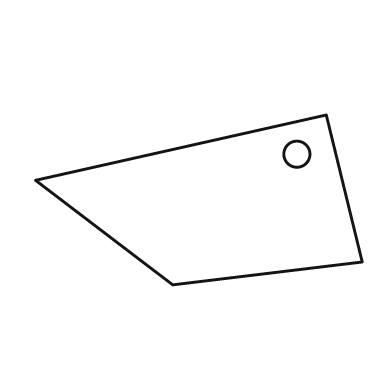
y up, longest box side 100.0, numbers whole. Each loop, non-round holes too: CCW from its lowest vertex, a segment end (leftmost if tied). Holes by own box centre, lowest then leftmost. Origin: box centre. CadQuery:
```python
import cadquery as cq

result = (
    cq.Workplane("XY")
    .moveTo(-8.0, -26.0)
    .lineTo(50.0, -19.0)
    .lineTo(39.0, 26.0)
    .lineTo(-50.0, 6.0)
    .close()
    .moveTo(30.0, 14.0)
    .circle(4.0)
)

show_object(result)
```